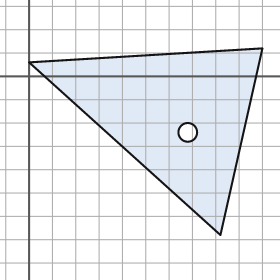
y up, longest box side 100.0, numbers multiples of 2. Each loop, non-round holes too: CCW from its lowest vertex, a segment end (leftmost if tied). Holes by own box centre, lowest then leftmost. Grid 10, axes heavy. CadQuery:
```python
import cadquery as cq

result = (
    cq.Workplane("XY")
    .moveTo(82.0, -68.0)
    .lineTo(100.0, 12.0)
    .lineTo(0.0, 6.0)
    .close()
    .moveTo(68.0, -24.0)
    .circle(4.0)
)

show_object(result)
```